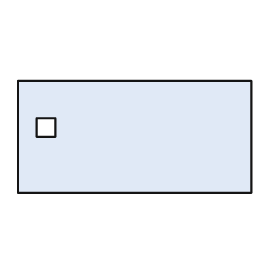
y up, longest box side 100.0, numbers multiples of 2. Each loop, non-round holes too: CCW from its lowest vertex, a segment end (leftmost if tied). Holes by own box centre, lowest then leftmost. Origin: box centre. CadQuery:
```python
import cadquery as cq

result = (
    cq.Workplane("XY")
    .moveTo(-50.0, -24.0)
    .lineTo(50.0, -24.0)
    .lineTo(50.0, 24.0)
    .lineTo(-50.0, 24.0)
    .close()
    .moveTo(-42.0, 0.0)
    .lineTo(-34.0, 0.0)
    .lineTo(-34.0, 8.0)
    .lineTo(-42.0, 8.0)
    .close()
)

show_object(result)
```